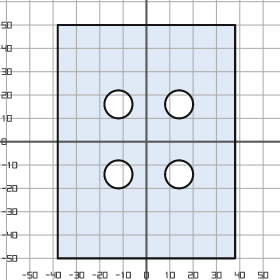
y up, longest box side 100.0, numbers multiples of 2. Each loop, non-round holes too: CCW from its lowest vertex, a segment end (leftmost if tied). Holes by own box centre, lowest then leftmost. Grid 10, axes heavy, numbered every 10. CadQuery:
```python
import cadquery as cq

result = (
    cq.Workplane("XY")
    .moveTo(-38.0, -50.0)
    .lineTo(38.0, -50.0)
    .lineTo(38.0, 50.0)
    .lineTo(-38.0, 50.0)
    .close()
    .moveTo(-12.0, -14.0)
    .circle(6.0)
    .moveTo(14.0, -14.0)
    .circle(6.0)
    .moveTo(-12.0, 16.0)
    .circle(6.0)
    .moveTo(14.0, 16.0)
    .circle(6.0)
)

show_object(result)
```